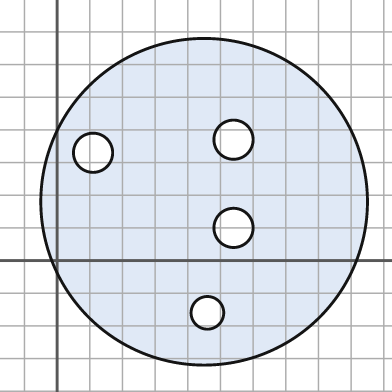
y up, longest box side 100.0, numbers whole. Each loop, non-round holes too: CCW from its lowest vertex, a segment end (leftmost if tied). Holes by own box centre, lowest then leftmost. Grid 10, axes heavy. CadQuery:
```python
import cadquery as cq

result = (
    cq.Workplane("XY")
    .moveTo(45.0, 18.0)
    .circle(50.0)
    .moveTo(46.0, -16.0)
    .circle(5.0)
    .moveTo(54.0, 10.0)
    .circle(6.0)
    .moveTo(11.0, 33.0)
    .circle(6.0)
    .moveTo(54.0, 37.0)
    .circle(6.0)
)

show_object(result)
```